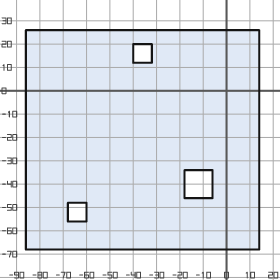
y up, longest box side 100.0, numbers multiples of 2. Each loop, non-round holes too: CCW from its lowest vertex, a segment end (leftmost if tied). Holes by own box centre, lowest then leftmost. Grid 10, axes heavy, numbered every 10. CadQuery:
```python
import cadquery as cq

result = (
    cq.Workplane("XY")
    .moveTo(-86.0, -68.0)
    .lineTo(14.0, -68.0)
    .lineTo(14.0, 26.0)
    .lineTo(-86.0, 26.0)
    .close()
    .moveTo(-68.0, -56.0)
    .lineTo(-60.0, -56.0)
    .lineTo(-60.0, -48.0)
    .lineTo(-68.0, -48.0)
    .close()
    .moveTo(-18.0, -46.0)
    .lineTo(-6.0, -46.0)
    .lineTo(-6.0, -34.0)
    .lineTo(-18.0, -34.0)
    .close()
    .moveTo(-40.0, 12.0)
    .lineTo(-32.0, 12.0)
    .lineTo(-32.0, 20.0)
    .lineTo(-40.0, 20.0)
    .close()
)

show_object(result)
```